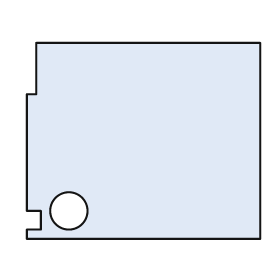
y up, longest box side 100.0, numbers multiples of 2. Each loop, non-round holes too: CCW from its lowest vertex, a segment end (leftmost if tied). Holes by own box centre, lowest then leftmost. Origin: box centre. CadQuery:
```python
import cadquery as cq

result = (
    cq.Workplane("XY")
    .moveTo(-50.0, -42.0)
    .lineTo(50.0, -42.0)
    .lineTo(50.0, 42.0)
    .lineTo(-46.0, 42.0)
    .lineTo(-46.0, 20.0)
    .lineTo(-50.0, 20.0)
    .lineTo(-50.0, -30.0)
    .lineTo(-44.0, -30.0)
    .lineTo(-44.0, -38.0)
    .lineTo(-50.0, -38.0)
    .close()
    .moveTo(-32.0, -30.0)
    .circle(8.0)
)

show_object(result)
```